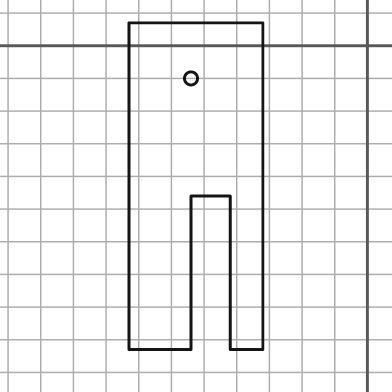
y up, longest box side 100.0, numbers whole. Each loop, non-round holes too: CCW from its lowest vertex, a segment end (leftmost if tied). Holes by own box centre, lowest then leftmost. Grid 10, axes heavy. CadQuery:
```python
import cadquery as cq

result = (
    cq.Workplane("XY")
    .moveTo(-73.0, -93.0)
    .lineTo(-54.0, -93.0)
    .lineTo(-54.0, -46.0)
    .lineTo(-42.0, -46.0)
    .lineTo(-42.0, -93.0)
    .lineTo(-32.0, -93.0)
    .lineTo(-32.0, 7.0)
    .lineTo(-73.0, 7.0)
    .close()
    .moveTo(-54.0, -10.0)
    .circle(2.0)
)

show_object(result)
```